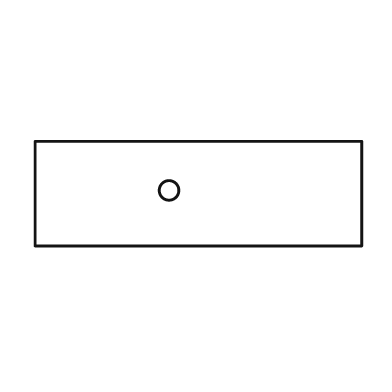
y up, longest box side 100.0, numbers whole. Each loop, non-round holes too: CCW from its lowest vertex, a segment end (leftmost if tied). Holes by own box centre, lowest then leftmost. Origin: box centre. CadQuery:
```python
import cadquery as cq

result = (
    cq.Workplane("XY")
    .moveTo(-50.0, -16.0)
    .lineTo(50.0, -16.0)
    .lineTo(50.0, 16.0)
    .lineTo(-50.0, 16.0)
    .close()
    .moveTo(-9.0, 1.0)
    .circle(3.0)
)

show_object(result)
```